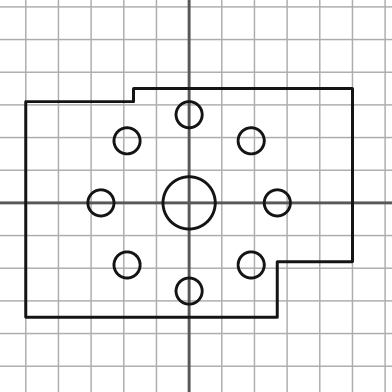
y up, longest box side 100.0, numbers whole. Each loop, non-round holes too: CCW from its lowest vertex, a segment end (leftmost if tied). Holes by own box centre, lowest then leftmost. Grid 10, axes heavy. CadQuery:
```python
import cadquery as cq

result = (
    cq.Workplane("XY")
    .moveTo(-50.0, -35.0)
    .lineTo(27.0, -35.0)
    .lineTo(27.0, -18.0)
    .lineTo(50.0, -18.0)
    .lineTo(50.0, 35.0)
    .lineTo(-17.0, 35.0)
    .lineTo(-17.0, 31.0)
    .lineTo(-50.0, 31.0)
    .close()
    .moveTo(0.0, -27.0)
    .circle(4.0)
    .moveTo(-19.0, -19.0)
    .circle(4.0)
    .moveTo(19.0, -19.0)
    .circle(4.0)
    .moveTo(-27.0, 0.0)
    .circle(4.0)
    .moveTo(0.0, 0.0)
    .circle(8.0)
    .moveTo(27.0, 0.0)
    .circle(4.0)
    .moveTo(-19.0, 19.0)
    .circle(4.0)
    .moveTo(19.0, 19.0)
    .circle(4.0)
    .moveTo(0.0, 27.0)
    .circle(4.0)
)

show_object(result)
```